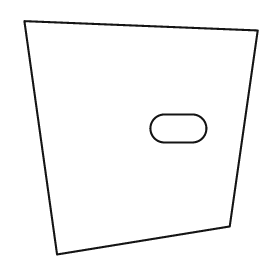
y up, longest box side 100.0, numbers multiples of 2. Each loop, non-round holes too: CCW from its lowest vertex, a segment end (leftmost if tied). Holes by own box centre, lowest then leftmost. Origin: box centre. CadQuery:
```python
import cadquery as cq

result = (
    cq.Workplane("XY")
    .moveTo(-36.0, -50.0)
    .lineTo(38.0, -38.0)
    .lineTo(50.0, 46.0)
    .lineTo(-50.0, 50.0)
    .close()
    .moveTo(10.0, -2.0)
    .lineTo(22.0, -2.0)
    .threePointArc((28.0, 4.0), (22.0, 10.0))
    .lineTo(10.0, 10.0)
    .threePointArc((4.0, 4.0), (10.0, -2.0))
    .close()
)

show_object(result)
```